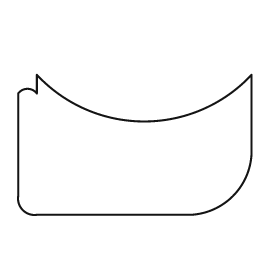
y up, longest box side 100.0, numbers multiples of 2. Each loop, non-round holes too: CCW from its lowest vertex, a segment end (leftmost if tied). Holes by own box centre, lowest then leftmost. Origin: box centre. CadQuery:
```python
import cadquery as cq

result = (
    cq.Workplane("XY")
    .moveTo(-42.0, -30.0)
    .lineTo(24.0, -30.0)
    .threePointArc((42.0, -22.0), (50.0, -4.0))
    .lineTo(50.0, 30.0)
    .threePointArc((4.0, 10.0), (-42.0, 30.0))
    .lineTo(-42.0, 22.0)
    .threePointArc((-46.0, 24.0), (-50.0, 22.0))
    .lineTo(-50.0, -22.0)
    .threePointArc((-48.0, -28.0), (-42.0, -30.0))
    .close()
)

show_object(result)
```